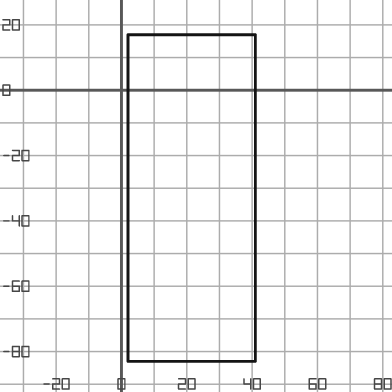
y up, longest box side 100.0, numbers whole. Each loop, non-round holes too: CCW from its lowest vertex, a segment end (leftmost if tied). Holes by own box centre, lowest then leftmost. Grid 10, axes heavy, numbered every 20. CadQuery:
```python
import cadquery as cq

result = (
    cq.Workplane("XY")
    .moveTo(2.0, -83.0)
    .lineTo(41.0, -83.0)
    .lineTo(41.0, 17.0)
    .lineTo(2.0, 17.0)
    .close()
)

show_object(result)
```